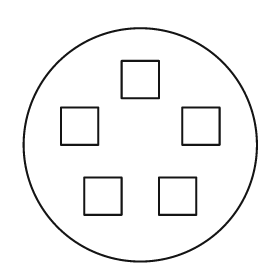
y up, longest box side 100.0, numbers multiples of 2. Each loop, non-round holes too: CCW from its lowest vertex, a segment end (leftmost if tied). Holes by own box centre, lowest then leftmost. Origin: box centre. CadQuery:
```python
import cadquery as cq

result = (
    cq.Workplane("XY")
    .moveTo(0.0, 0.0)
    .circle(50.0)
    .moveTo(-24.0, -30.0)
    .lineTo(-8.0, -30.0)
    .lineTo(-8.0, -14.0)
    .lineTo(-24.0, -14.0)
    .close()
    .moveTo(8.0, -30.0)
    .lineTo(24.0, -30.0)
    .lineTo(24.0, -14.0)
    .lineTo(8.0, -14.0)
    .close()
    .moveTo(-34.0, 0.0)
    .lineTo(-18.0, 0.0)
    .lineTo(-18.0, 16.0)
    .lineTo(-34.0, 16.0)
    .close()
    .moveTo(18.0, 0.0)
    .lineTo(34.0, 0.0)
    .lineTo(34.0, 16.0)
    .lineTo(18.0, 16.0)
    .close()
    .moveTo(-8.0, 20.0)
    .lineTo(8.0, 20.0)
    .lineTo(8.0, 36.0)
    .lineTo(-8.0, 36.0)
    .close()
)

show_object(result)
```